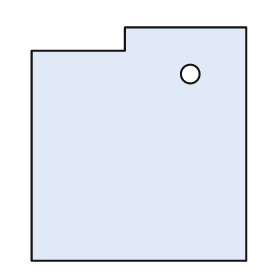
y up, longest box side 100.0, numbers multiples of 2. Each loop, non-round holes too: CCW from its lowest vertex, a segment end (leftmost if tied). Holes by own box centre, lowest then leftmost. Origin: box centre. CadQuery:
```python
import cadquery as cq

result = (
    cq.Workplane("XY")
    .moveTo(-46.0, -50.0)
    .lineTo(46.0, -50.0)
    .lineTo(46.0, 50.0)
    .lineTo(-6.0, 50.0)
    .lineTo(-6.0, 40.0)
    .lineTo(-46.0, 40.0)
    .close()
    .moveTo(22.0, 30.0)
    .circle(4.0)
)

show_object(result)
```